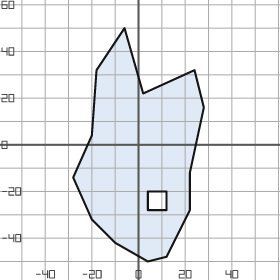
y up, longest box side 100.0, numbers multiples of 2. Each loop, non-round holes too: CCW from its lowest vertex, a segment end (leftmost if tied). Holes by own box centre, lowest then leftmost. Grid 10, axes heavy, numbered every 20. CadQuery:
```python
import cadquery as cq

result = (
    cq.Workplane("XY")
    .moveTo(4.0, -50.0)
    .lineTo(12.0, -48.0)
    .lineTo(22.0, -28.0)
    .lineTo(22.0, -12.0)
    .lineTo(28.0, 16.0)
    .lineTo(24.0, 32.0)
    .lineTo(2.0, 22.0)
    .lineTo(-6.0, 50.0)
    .lineTo(-18.0, 32.0)
    .lineTo(-20.0, 4.0)
    .lineTo(-28.0, -14.0)
    .lineTo(-20.0, -32.0)
    .lineTo(-10.0, -42.0)
    .close()
    .moveTo(4.0, -28.0)
    .lineTo(12.0, -28.0)
    .lineTo(12.0, -20.0)
    .lineTo(4.0, -20.0)
    .close()
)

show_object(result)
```